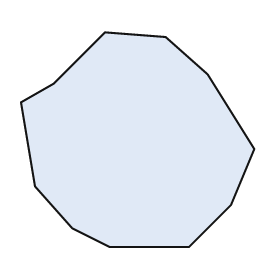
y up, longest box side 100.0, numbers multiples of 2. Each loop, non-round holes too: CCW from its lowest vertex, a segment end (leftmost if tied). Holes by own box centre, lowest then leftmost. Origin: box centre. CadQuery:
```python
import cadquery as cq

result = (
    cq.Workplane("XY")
    .moveTo(-12.0, -46.0)
    .lineTo(22.0, -46.0)
    .lineTo(40.0, -28.0)
    .lineTo(50.0, -4.0)
    .lineTo(30.0, 28.0)
    .lineTo(12.0, 44.0)
    .lineTo(-14.0, 46.0)
    .lineTo(-36.0, 24.0)
    .lineTo(-50.0, 16.0)
    .lineTo(-44.0, -20.0)
    .lineTo(-28.0, -38.0)
    .close()
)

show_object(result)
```